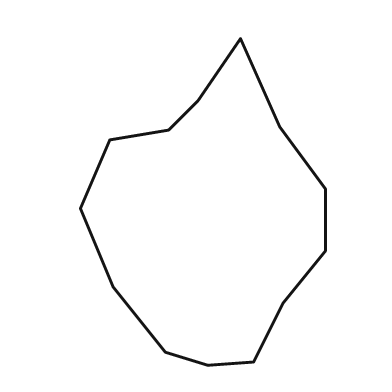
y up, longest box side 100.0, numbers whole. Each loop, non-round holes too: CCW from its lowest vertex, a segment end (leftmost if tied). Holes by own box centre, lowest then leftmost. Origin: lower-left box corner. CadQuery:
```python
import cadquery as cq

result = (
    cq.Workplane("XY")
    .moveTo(39.0, 0.0)
    .lineTo(53.0, 1.0)
    .lineTo(62.0, 19.0)
    .lineTo(75.0, 35.0)
    .lineTo(75.0, 54.0)
    .lineTo(61.0, 73.0)
    .lineTo(49.0, 100.0)
    .lineTo(36.0, 81.0)
    .lineTo(27.0, 72.0)
    .lineTo(9.0, 69.0)
    .lineTo(0.0, 48.0)
    .lineTo(10.0, 24.0)
    .lineTo(26.0, 4.0)
    .close()
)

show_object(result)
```